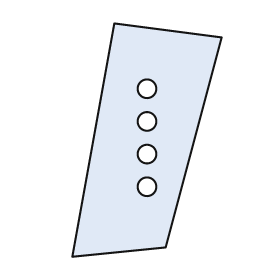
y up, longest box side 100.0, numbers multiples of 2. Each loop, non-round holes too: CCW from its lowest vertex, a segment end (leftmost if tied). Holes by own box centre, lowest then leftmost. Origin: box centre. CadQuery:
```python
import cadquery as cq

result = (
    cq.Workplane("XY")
    .moveTo(-32.0, -50.0)
    .lineTo(8.0, -46.0)
    .lineTo(32.0, 44.0)
    .lineTo(-14.0, 50.0)
    .close()
    .moveTo(0.0, -20.0)
    .circle(4.0)
    .moveTo(0.0, -6.0)
    .circle(4.0)
    .moveTo(0.0, 8.0)
    .circle(4.0)
    .moveTo(0.0, 22.0)
    .circle(4.0)
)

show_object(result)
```